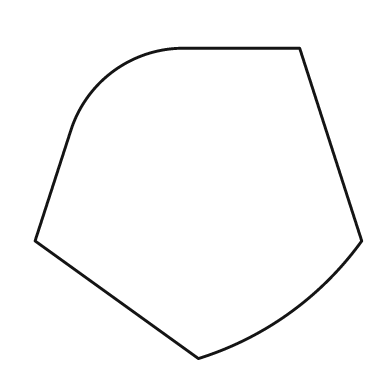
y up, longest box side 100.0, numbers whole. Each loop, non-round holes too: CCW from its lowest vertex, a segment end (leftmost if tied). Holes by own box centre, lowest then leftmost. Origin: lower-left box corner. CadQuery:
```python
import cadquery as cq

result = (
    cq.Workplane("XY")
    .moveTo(50.0, 0.0)
    .threePointArc((78.0, 14.0), (100.0, 36.0))
    .lineTo(81.0, 95.0)
    .lineTo(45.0, 95.0)
    .threePointArc((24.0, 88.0), (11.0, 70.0))
    .lineTo(0.0, 36.0)
    .close()
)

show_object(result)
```